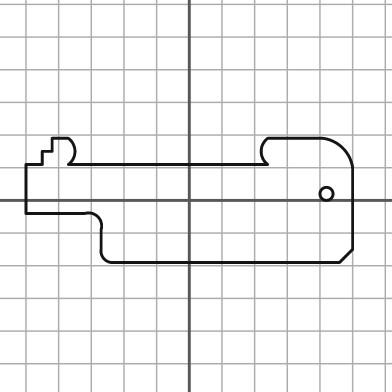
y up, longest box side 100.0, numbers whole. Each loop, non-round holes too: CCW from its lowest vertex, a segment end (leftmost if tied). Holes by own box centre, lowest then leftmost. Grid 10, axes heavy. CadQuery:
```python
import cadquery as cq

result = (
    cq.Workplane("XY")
    .moveTo(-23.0, -19.0)
    .lineTo(46.0, -19.0)
    .lineTo(50.0, -15.0)
    .lineTo(50.0, 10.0)
    .threePointArc((47.0, 16.0), (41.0, 19.0))
    .lineTo(24.0, 19.0)
    .threePointArc((22.0, 15.0), (24.0, 11.0))
    .lineTo(-37.0, 11.0)
    .threePointArc((-35.0, 15.0), (-37.0, 19.0))
    .lineTo(-42.0, 19.0)
    .lineTo(-42.0, 15.0)
    .lineTo(-45.0, 15.0)
    .lineTo(-45.0, 11.0)
    .lineTo(-50.0, 11.0)
    .lineTo(-50.0, -4.0)
    .lineTo(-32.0, -4.0)
    .threePointArc((-28.0, -5.0), (-27.0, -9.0))
    .lineTo(-27.0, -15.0)
    .threePointArc((-26.0, -18.0), (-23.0, -19.0))
    .close()
    .moveTo(42.0, 2.0)
    .circle(2.0)
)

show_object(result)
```